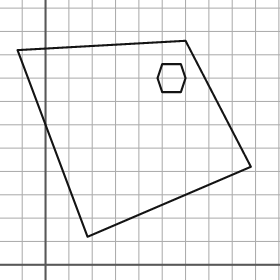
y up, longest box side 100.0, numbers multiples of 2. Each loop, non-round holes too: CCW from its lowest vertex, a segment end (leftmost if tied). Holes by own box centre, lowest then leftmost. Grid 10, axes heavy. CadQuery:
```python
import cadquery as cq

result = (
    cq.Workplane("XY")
    .moveTo(18.0, 12.0)
    .lineTo(88.0, 42.0)
    .lineTo(60.0, 96.0)
    .lineTo(-12.0, 92.0)
    .close()
    .moveTo(50.0, 74.0)
    .lineTo(58.0, 74.0)
    .lineTo(60.0, 80.0)
    .lineTo(58.0, 86.0)
    .lineTo(50.0, 86.0)
    .lineTo(48.0, 80.0)
    .close()
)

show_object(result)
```